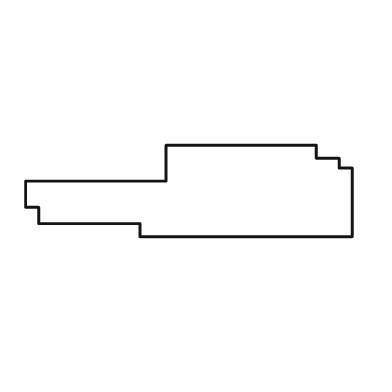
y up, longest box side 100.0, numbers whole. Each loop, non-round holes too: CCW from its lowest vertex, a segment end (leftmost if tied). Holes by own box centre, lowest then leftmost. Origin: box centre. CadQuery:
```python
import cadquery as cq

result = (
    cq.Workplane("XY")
    .moveTo(-15.0, -14.0)
    .lineTo(50.0, -14.0)
    .lineTo(50.0, 7.0)
    .lineTo(46.0, 7.0)
    .lineTo(46.0, 10.0)
    .lineTo(39.0, 10.0)
    .lineTo(39.0, 14.0)
    .lineTo(-7.0, 14.0)
    .lineTo(-7.0, 3.0)
    .lineTo(-50.0, 3.0)
    .lineTo(-50.0, -5.0)
    .lineTo(-46.0, -5.0)
    .lineTo(-46.0, -10.0)
    .lineTo(-15.0, -10.0)
    .close()
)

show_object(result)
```